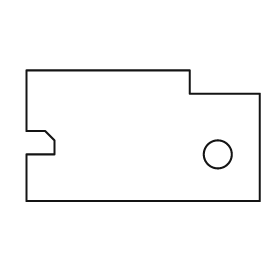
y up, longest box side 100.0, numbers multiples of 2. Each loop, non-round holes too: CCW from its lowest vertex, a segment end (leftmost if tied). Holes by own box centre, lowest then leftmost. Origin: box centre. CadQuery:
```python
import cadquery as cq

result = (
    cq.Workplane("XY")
    .moveTo(-50.0, -28.0)
    .lineTo(50.0, -28.0)
    .lineTo(50.0, 18.0)
    .lineTo(20.0, 18.0)
    .lineTo(20.0, 28.0)
    .lineTo(-50.0, 28.0)
    .lineTo(-50.0, 2.0)
    .lineTo(-42.0, 2.0)
    .lineTo(-38.0, -2.0)
    .lineTo(-38.0, -8.0)
    .lineTo(-50.0, -8.0)
    .close()
    .moveTo(32.0, -8.0)
    .circle(6.0)
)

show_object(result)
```